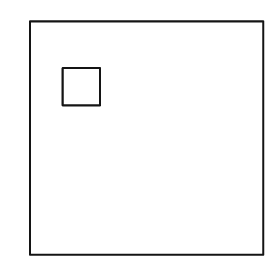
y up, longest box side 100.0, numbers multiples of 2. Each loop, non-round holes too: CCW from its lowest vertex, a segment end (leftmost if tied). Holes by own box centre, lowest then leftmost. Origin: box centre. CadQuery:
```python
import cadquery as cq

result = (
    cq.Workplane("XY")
    .moveTo(-50.0, -50.0)
    .lineTo(50.0, -50.0)
    .lineTo(50.0, 50.0)
    .lineTo(-50.0, 50.0)
    .close()
    .moveTo(-36.0, 14.0)
    .lineTo(-20.0, 14.0)
    .lineTo(-20.0, 30.0)
    .lineTo(-36.0, 30.0)
    .close()
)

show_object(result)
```